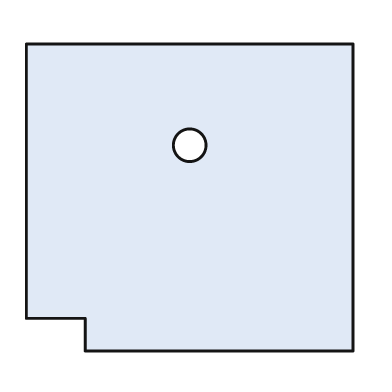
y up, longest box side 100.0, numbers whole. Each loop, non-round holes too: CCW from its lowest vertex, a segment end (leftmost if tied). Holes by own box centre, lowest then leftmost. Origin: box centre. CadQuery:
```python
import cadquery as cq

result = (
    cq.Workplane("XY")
    .moveTo(-32.0, -47.0)
    .lineTo(50.0, -47.0)
    .lineTo(50.0, 47.0)
    .lineTo(-50.0, 47.0)
    .lineTo(-50.0, -37.0)
    .lineTo(-32.0, -37.0)
    .close()
    .moveTo(0.0, 16.0)
    .circle(5.0)
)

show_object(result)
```